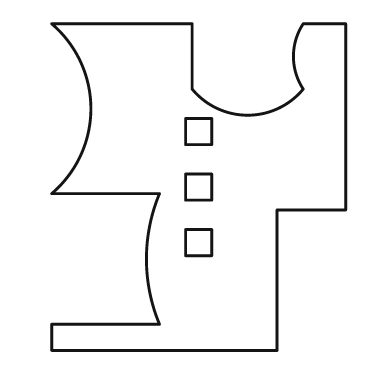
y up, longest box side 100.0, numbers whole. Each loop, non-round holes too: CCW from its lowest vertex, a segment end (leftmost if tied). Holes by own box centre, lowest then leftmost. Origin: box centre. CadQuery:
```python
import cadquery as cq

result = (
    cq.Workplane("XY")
    .moveTo(-45.0, -50.0)
    .lineTo(24.0, -50.0)
    .lineTo(24.0, -7.0)
    .lineTo(45.0, -7.0)
    .lineTo(45.0, 50.0)
    .lineTo(32.0, 50.0)
    .threePointArc((29.0, 40.0), (32.0, 30.0))
    .threePointArc((15.0, 22.0), (-2.0, 30.0))
    .lineTo(-2.0, 50.0)
    .lineTo(-45.0, 50.0)
    .threePointArc((-33.0, 24.0), (-45.0, -2.0))
    .lineTo(-12.0, -2.0)
    .threePointArc((-16.0, -22.0), (-12.0, -42.0))
    .lineTo(-45.0, -42.0)
    .close()
    .moveTo(-4.0, -21.0)
    .lineTo(4.0, -21.0)
    .lineTo(4.0, -13.0)
    .lineTo(-4.0, -13.0)
    .close()
    .moveTo(-4.0, -4.0)
    .lineTo(4.0, -4.0)
    .lineTo(4.0, 4.0)
    .lineTo(-4.0, 4.0)
    .close()
    .moveTo(-4.0, 13.0)
    .lineTo(4.0, 13.0)
    .lineTo(4.0, 21.0)
    .lineTo(-4.0, 21.0)
    .close()
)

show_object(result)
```